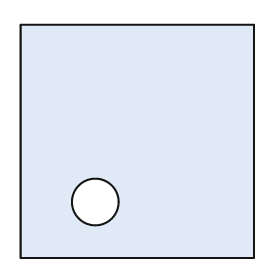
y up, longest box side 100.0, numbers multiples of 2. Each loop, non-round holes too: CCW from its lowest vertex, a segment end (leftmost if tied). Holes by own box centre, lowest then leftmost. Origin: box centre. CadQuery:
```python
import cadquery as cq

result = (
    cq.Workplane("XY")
    .moveTo(-50.0, -50.0)
    .lineTo(50.0, -50.0)
    .lineTo(50.0, 50.0)
    .lineTo(-50.0, 50.0)
    .close()
    .moveTo(-18.0, -26.0)
    .circle(10.0)
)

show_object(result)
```